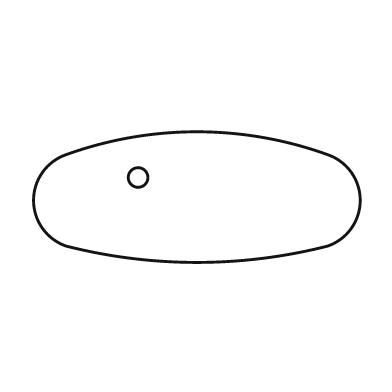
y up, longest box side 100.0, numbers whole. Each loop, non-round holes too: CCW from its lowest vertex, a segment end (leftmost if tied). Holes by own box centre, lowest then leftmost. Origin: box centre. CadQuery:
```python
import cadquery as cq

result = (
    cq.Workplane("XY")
    .moveTo(-40.0, -15.0)
    .threePointArc((0.0, -20.0), (40.0, -15.0))
    .threePointArc((50.0, -1.0), (40.0, 13.0))
    .threePointArc((0.0, 20.0), (-40.0, 13.0))
    .threePointArc((-50.0, -1.0), (-40.0, -15.0))
    .close()
    .moveTo(-18.0, 6.0)
    .circle(3.0)
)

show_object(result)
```